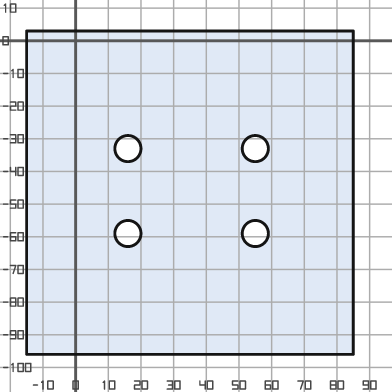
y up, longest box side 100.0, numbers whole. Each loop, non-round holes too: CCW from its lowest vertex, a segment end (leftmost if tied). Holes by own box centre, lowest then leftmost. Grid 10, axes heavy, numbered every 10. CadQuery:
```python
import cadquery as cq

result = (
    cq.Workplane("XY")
    .moveTo(-15.0, -96.0)
    .lineTo(85.0, -96.0)
    .lineTo(85.0, 3.0)
    .lineTo(-15.0, 3.0)
    .close()
    .moveTo(16.0, -59.0)
    .circle(4.0)
    .moveTo(55.0, -59.0)
    .circle(4.0)
    .moveTo(16.0, -33.0)
    .circle(4.0)
    .moveTo(55.0, -33.0)
    .circle(4.0)
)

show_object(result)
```